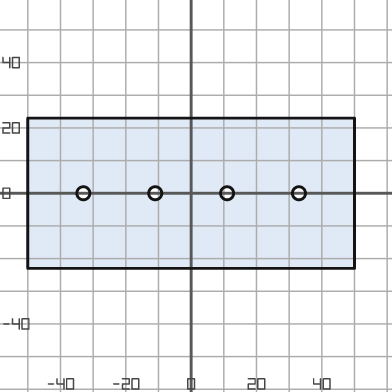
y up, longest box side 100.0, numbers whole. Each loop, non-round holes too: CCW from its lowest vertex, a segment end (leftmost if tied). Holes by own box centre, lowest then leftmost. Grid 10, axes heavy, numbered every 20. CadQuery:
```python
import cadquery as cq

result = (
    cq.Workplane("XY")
    .moveTo(-50.0, -23.0)
    .lineTo(50.0, -23.0)
    .lineTo(50.0, 23.0)
    .lineTo(-50.0, 23.0)
    .close()
    .moveTo(-33.0, 0.0)
    .circle(2.0)
    .moveTo(-11.0, 0.0)
    .circle(2.0)
    .moveTo(11.0, 0.0)
    .circle(2.0)
    .moveTo(33.0, 0.0)
    .circle(2.0)
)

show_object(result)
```